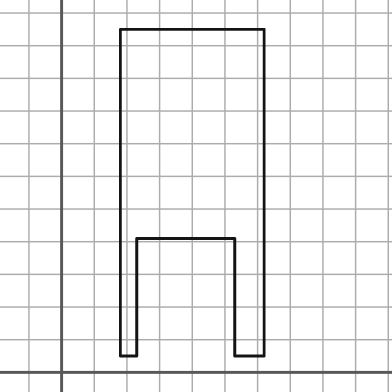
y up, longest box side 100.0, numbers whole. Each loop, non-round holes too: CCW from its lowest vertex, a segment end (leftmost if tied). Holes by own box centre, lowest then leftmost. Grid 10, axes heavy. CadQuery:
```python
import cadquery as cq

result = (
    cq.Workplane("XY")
    .moveTo(18.0, 5.0)
    .lineTo(23.0, 5.0)
    .lineTo(23.0, 41.0)
    .lineTo(53.0, 41.0)
    .lineTo(53.0, 5.0)
    .lineTo(62.0, 5.0)
    .lineTo(62.0, 105.0)
    .lineTo(18.0, 105.0)
    .close()
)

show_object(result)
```